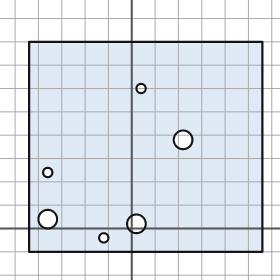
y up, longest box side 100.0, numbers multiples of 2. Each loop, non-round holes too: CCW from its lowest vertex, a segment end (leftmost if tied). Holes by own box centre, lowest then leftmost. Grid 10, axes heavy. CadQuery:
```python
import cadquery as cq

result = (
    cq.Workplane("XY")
    .moveTo(-44.0, -10.0)
    .lineTo(56.0, -10.0)
    .lineTo(56.0, 80.0)
    .lineTo(-44.0, 80.0)
    .close()
    .moveTo(-12.0, -4.0)
    .circle(2.0)
    .moveTo(2.0, 2.0)
    .circle(4.0)
    .moveTo(-36.0, 4.0)
    .circle(4.0)
    .moveTo(-36.0, 24.0)
    .circle(2.0)
    .moveTo(22.0, 38.0)
    .circle(4.0)
    .moveTo(4.0, 60.0)
    .circle(2.0)
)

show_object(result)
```